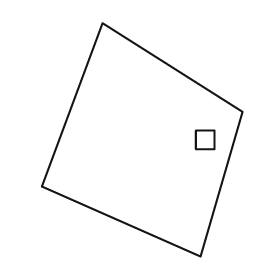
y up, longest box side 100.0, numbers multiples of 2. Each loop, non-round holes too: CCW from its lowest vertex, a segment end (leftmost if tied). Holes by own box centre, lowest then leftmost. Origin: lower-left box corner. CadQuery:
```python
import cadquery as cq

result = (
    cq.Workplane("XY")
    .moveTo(68.0, 0.0)
    .lineTo(86.0, 62.0)
    .lineTo(26.0, 100.0)
    .lineTo(0.0, 30.0)
    .close()
    .moveTo(66.0, 46.0)
    .lineTo(74.0, 46.0)
    .lineTo(74.0, 54.0)
    .lineTo(66.0, 54.0)
    .close()
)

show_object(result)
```